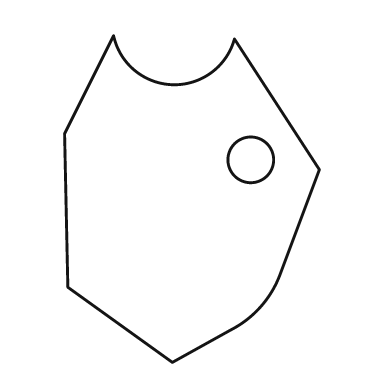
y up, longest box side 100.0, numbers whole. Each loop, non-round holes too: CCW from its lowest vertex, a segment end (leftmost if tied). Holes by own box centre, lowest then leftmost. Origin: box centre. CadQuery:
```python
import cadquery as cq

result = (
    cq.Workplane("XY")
    .moveTo(-6.0, -50.0)
    .lineTo(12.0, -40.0)
    .threePointArc((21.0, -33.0), (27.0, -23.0))
    .lineTo(39.0, 9.0)
    .lineTo(13.0, 49.0)
    .threePointArc((-6.0, 35.0), (-24.0, 50.0))
    .lineTo(-39.0, 20.0)
    .lineTo(-38.0, -27.0)
    .close()
    .moveTo(18.0, 12.0)
    .circle(7.0)
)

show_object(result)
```